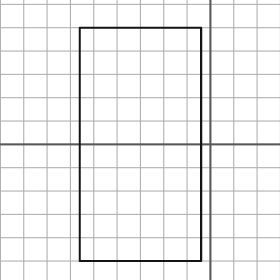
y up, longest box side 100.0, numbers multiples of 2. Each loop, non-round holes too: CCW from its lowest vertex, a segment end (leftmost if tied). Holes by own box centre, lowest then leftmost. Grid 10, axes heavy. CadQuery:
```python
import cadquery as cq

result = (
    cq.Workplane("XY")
    .moveTo(-56.0, -50.0)
    .lineTo(-4.0, -50.0)
    .lineTo(-4.0, 50.0)
    .lineTo(-56.0, 50.0)
    .close()
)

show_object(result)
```